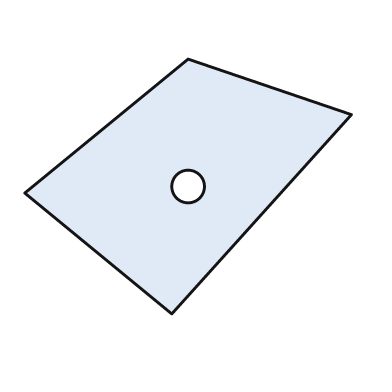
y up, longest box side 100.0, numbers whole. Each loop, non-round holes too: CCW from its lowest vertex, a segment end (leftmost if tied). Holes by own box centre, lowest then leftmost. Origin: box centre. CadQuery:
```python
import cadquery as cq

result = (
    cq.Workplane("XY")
    .moveTo(-5.0, -39.0)
    .lineTo(50.0, 22.0)
    .lineTo(0.0, 39.0)
    .lineTo(-50.0, -2.0)
    .close()
    .moveTo(0.0, 0.0)
    .circle(5.0)
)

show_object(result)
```